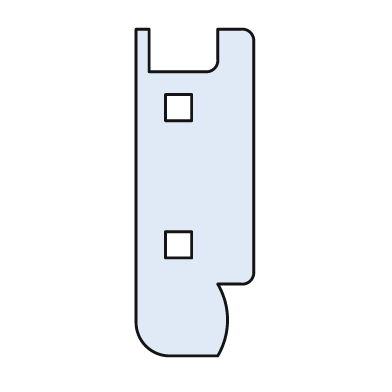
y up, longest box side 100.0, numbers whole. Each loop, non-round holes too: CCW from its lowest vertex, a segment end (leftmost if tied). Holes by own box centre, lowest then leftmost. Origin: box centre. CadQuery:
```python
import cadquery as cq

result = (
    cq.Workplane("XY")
    .moveTo(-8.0, -50.0)
    .lineTo(7.0, -50.0)
    .threePointArc((10.0, -39.0), (7.0, -28.0))
    .lineTo(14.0, -28.0)
    .threePointArc((17.0, -27.0), (18.0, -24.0))
    .lineTo(18.0, 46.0)
    .threePointArc((17.0, 49.0), (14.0, 50.0))
    .lineTo(7.0, 50.0)
    .lineTo(7.0, 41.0)
    .threePointArc((6.0, 38.0), (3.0, 37.0))
    .lineTo(-14.0, 37.0)
    .lineTo(-14.0, 50.0)
    .lineTo(-18.0, 50.0)
    .lineTo(-18.0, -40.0)
    .threePointArc((-15.0, -47.0), (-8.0, -50.0))
    .close()
    .moveTo(-9.0, -20.0)
    .lineTo(-1.0, -20.0)
    .lineTo(-1.0, -12.0)
    .lineTo(-9.0, -12.0)
    .close()
    .moveTo(-9.0, 22.0)
    .lineTo(-1.0, 22.0)
    .lineTo(-1.0, 30.0)
    .lineTo(-9.0, 30.0)
    .close()
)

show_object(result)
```